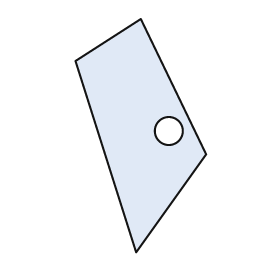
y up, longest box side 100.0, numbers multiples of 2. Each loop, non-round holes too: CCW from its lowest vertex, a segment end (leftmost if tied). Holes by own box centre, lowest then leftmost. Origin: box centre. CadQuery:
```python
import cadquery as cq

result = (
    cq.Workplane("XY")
    .moveTo(-2.0, -50.0)
    .lineTo(28.0, -8.0)
    .lineTo(0.0, 50.0)
    .lineTo(-28.0, 32.0)
    .close()
    .moveTo(12.0, 2.0)
    .circle(6.0)
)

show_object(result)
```